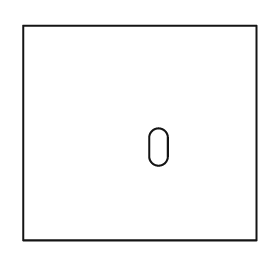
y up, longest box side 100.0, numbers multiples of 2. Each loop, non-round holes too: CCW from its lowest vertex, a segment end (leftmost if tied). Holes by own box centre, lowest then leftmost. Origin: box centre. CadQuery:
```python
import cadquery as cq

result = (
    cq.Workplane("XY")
    .moveTo(-50.0, -46.0)
    .lineTo(50.0, -46.0)
    .lineTo(50.0, 46.0)
    .lineTo(-50.0, 46.0)
    .close()
    .moveTo(4.0, -10.0)
    .threePointArc((8.0, -14.0), (12.0, -10.0))
    .lineTo(12.0, -2.0)
    .threePointArc((8.0, 2.0), (4.0, -2.0))
    .close()
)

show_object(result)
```